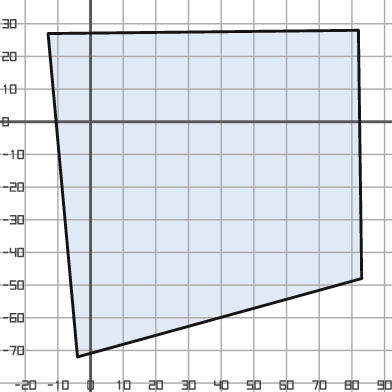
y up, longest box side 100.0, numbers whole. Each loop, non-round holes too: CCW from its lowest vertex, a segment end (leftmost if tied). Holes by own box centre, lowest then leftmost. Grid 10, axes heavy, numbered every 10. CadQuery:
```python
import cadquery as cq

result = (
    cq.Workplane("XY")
    .moveTo(-4.0, -72.0)
    .lineTo(83.0, -48.0)
    .lineTo(82.0, 28.0)
    .lineTo(-13.0, 27.0)
    .close()
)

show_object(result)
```